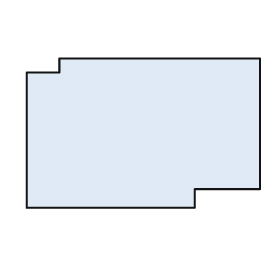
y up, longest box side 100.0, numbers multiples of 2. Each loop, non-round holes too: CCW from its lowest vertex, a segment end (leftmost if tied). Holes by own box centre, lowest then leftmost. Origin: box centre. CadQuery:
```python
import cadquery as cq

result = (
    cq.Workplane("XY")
    .moveTo(-50.0, -32.0)
    .lineTo(22.0, -32.0)
    .lineTo(22.0, -24.0)
    .lineTo(50.0, -24.0)
    .lineTo(50.0, 32.0)
    .lineTo(-36.0, 32.0)
    .lineTo(-36.0, 26.0)
    .lineTo(-50.0, 26.0)
    .close()
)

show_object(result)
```